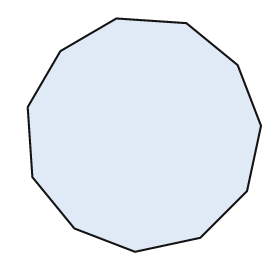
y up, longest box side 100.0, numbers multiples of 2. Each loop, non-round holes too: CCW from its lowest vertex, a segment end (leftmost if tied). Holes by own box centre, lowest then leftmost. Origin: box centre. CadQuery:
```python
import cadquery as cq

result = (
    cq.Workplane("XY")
    .moveTo(-4.0, -50.0)
    .lineTo(24.0, -44.0)
    .lineTo(44.0, -24.0)
    .lineTo(50.0, 4.0)
    .lineTo(40.0, 30.0)
    .lineTo(18.0, 48.0)
    .lineTo(-12.0, 50.0)
    .lineTo(-36.0, 36.0)
    .lineTo(-50.0, 12.0)
    .lineTo(-48.0, -18.0)
    .lineTo(-30.0, -40.0)
    .close()
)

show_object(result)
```